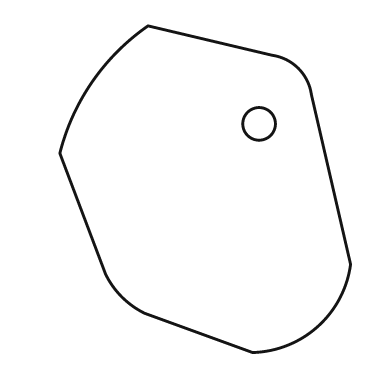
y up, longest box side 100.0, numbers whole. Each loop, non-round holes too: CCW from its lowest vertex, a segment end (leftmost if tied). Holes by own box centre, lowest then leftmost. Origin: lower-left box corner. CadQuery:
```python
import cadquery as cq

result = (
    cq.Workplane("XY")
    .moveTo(59.0, 0.0)
    .threePointArc((79.0, 8.0), (89.0, 27.0))
    .lineTo(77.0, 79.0)
    .threePointArc((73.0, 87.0), (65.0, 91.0))
    .lineTo(27.0, 100.0)
    .threePointArc((10.0, 83.0), (0.0, 61.0))
    .lineTo(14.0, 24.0)
    .threePointArc((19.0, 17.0), (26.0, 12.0))
    .close()
    .moveTo(61.0, 70.0)
    .circle(5.0)
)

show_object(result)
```